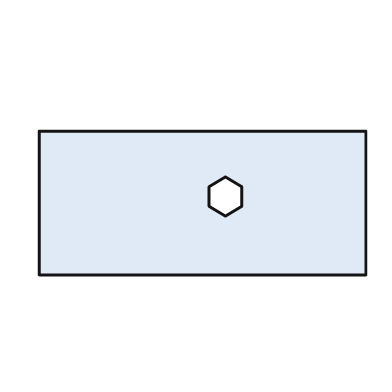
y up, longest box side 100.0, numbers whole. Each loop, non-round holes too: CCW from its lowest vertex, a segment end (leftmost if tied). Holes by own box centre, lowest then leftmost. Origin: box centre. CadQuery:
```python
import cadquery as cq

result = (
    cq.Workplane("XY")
    .moveTo(-50.0, -22.0)
    .lineTo(50.0, -22.0)
    .lineTo(50.0, 22.0)
    .lineTo(-50.0, 22.0)
    .close()
    .moveTo(7.0, -4.0)
    .lineTo(12.0, -1.0)
    .lineTo(12.0, 5.0)
    .lineTo(7.0, 8.0)
    .lineTo(2.0, 5.0)
    .lineTo(2.0, -1.0)
    .close()
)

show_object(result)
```